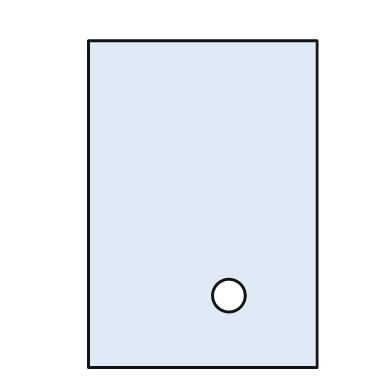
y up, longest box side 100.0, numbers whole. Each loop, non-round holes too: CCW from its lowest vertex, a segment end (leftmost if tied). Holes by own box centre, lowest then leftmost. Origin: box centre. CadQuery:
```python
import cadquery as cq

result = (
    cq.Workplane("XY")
    .moveTo(-35.0, -50.0)
    .lineTo(35.0, -50.0)
    .lineTo(35.0, 50.0)
    .lineTo(-35.0, 50.0)
    .close()
    .moveTo(8.0, -28.0)
    .circle(5.0)
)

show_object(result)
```